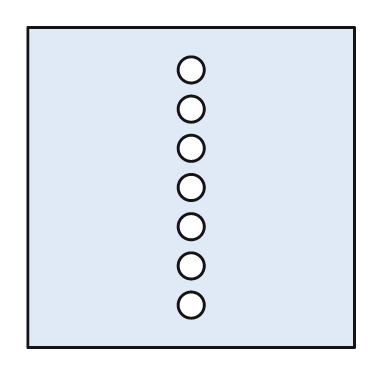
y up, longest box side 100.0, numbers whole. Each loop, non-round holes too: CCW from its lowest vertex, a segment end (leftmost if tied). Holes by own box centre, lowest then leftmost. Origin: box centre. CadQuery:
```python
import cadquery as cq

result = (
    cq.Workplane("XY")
    .moveTo(-50.0, -49.0)
    .lineTo(50.0, -49.0)
    .lineTo(50.0, 49.0)
    .lineTo(-50.0, 49.0)
    .close()
    .moveTo(0.0, -36.0)
    .circle(4.0)
    .moveTo(0.0, -24.0)
    .circle(4.0)
    .moveTo(0.0, -12.0)
    .circle(4.0)
    .moveTo(0.0, 0.0)
    .circle(4.0)
    .moveTo(0.0, 12.0)
    .circle(4.0)
    .moveTo(0.0, 24.0)
    .circle(4.0)
    .moveTo(0.0, 36.0)
    .circle(4.0)
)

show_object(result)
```